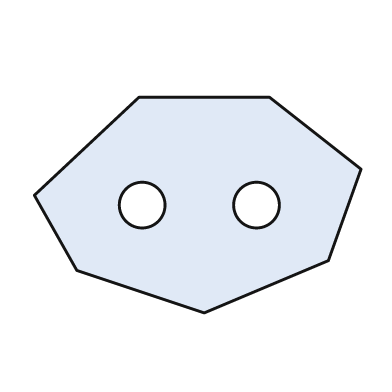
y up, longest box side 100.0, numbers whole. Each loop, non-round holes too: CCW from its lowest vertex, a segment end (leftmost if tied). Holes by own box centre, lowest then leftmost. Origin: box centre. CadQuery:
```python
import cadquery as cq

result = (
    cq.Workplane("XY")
    .moveTo(2.0, -33.0)
    .lineTo(40.0, -17.0)
    .lineTo(50.0, 11.0)
    .lineTo(22.0, 33.0)
    .lineTo(-18.0, 33.0)
    .lineTo(-50.0, 3.0)
    .lineTo(-37.0, -20.0)
    .close()
    .moveTo(-17.0, 0.0)
    .circle(7.0)
    .moveTo(18.0, 0.0)
    .circle(7.0)
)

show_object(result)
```